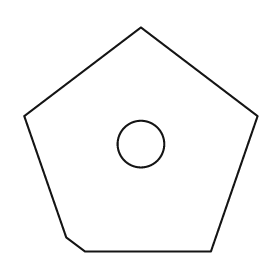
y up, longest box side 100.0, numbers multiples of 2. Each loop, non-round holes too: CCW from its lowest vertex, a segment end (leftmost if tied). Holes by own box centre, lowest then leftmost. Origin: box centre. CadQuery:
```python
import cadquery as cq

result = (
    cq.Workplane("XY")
    .moveTo(-24.0, -48.0)
    .lineTo(30.0, -48.0)
    .lineTo(50.0, 10.0)
    .lineTo(0.0, 48.0)
    .lineTo(-50.0, 10.0)
    .lineTo(-32.0, -42.0)
    .close()
    .moveTo(0.0, -2.0)
    .circle(10.0)
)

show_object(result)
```